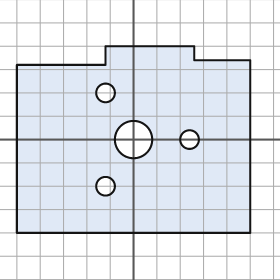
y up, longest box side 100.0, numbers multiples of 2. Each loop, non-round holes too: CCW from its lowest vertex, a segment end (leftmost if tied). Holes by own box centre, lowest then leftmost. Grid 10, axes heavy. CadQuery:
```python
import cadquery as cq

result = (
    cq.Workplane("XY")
    .moveTo(-50.0, -40.0)
    .lineTo(50.0, -40.0)
    .lineTo(50.0, 34.0)
    .lineTo(26.0, 34.0)
    .lineTo(26.0, 40.0)
    .lineTo(-12.0, 40.0)
    .lineTo(-12.0, 32.0)
    .lineTo(-50.0, 32.0)
    .close()
    .moveTo(-12.0, -20.0)
    .circle(4.0)
    .moveTo(0.0, 0.0)
    .circle(8.0)
    .moveTo(24.0, 0.0)
    .circle(4.0)
    .moveTo(-12.0, 20.0)
    .circle(4.0)
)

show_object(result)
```